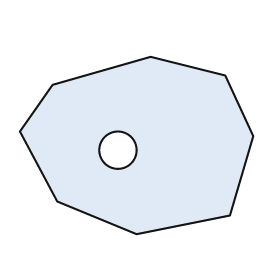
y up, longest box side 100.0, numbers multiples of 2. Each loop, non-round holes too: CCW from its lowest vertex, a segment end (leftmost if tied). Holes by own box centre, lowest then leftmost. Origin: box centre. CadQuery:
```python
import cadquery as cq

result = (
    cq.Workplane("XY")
    .moveTo(0.0, -38.0)
    .lineTo(40.0, -30.0)
    .lineTo(50.0, 4.0)
    .lineTo(38.0, 30.0)
    .lineTo(6.0, 38.0)
    .lineTo(-36.0, 26.0)
    .lineTo(-50.0, 6.0)
    .lineTo(-34.0, -24.0)
    .close()
    .moveTo(-8.0, -2.0)
    .circle(8.0)
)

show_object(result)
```